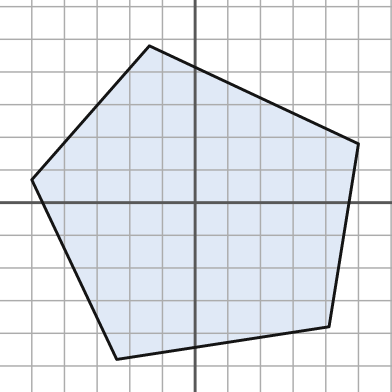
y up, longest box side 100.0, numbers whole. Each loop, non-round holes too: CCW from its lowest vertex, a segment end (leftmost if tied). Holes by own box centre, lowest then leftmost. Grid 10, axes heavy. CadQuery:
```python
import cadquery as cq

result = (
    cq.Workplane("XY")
    .moveTo(-24.0, -48.0)
    .lineTo(41.0, -38.0)
    .lineTo(50.0, 18.0)
    .lineTo(-14.0, 48.0)
    .lineTo(-50.0, 7.0)
    .close()
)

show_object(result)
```